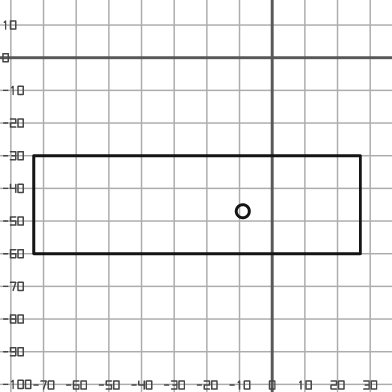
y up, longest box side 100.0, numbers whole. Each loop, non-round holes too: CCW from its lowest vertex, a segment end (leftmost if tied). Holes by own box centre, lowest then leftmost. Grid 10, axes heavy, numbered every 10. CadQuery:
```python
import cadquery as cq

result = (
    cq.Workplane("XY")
    .moveTo(-73.0, -60.0)
    .lineTo(27.0, -60.0)
    .lineTo(27.0, -30.0)
    .lineTo(-73.0, -30.0)
    .close()
    .moveTo(-9.0, -47.0)
    .circle(2.0)
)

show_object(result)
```